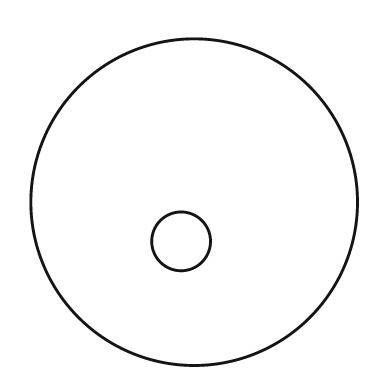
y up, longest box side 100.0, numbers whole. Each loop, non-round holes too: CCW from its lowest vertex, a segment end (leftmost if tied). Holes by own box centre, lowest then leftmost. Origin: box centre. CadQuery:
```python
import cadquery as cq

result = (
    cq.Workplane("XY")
    .moveTo(0.0, 0.0)
    .circle(50.0)
    .moveTo(-4.0, -12.0)
    .circle(9.0)
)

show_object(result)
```